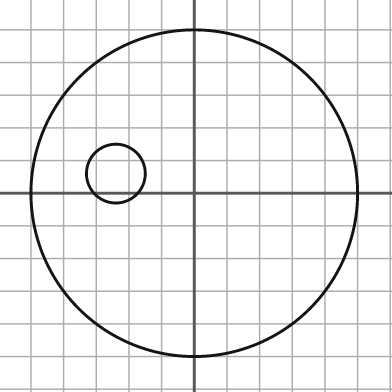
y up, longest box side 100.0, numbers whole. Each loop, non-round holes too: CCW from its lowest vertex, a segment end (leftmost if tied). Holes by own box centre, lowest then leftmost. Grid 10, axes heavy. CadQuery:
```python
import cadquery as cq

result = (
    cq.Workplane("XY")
    .moveTo(0.0, 0.0)
    .circle(50.0)
    .moveTo(-24.0, 6.0)
    .circle(9.0)
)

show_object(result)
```